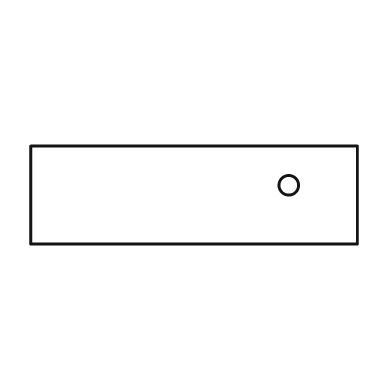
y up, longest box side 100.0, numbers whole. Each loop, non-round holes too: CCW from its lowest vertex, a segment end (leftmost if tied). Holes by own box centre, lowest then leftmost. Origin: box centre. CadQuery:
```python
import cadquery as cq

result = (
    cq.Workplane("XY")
    .moveTo(-50.0, -15.0)
    .lineTo(50.0, -15.0)
    .lineTo(50.0, 15.0)
    .lineTo(-50.0, 15.0)
    .close()
    .moveTo(29.0, 3.0)
    .circle(3.0)
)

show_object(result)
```